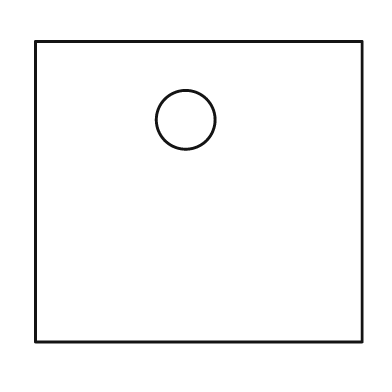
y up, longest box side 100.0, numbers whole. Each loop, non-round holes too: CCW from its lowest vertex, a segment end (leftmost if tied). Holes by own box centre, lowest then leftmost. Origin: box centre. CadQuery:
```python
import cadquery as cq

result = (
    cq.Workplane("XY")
    .moveTo(-50.0, -46.0)
    .lineTo(50.0, -46.0)
    .lineTo(50.0, 46.0)
    .lineTo(-50.0, 46.0)
    .close()
    .moveTo(-4.0, 22.0)
    .circle(9.0)
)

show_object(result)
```